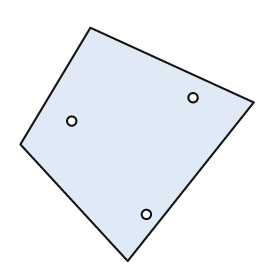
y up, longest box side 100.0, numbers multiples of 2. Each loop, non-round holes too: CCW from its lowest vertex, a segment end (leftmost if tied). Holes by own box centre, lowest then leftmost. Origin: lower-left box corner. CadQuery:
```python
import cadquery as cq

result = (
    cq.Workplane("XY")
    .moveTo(46.0, 0.0)
    .lineTo(100.0, 68.0)
    .lineTo(30.0, 100.0)
    .lineTo(0.0, 50.0)
    .close()
    .moveTo(54.0, 20.0)
    .circle(2.0)
    .moveTo(22.0, 60.0)
    .circle(2.0)
    .moveTo(74.0, 70.0)
    .circle(2.0)
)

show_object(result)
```